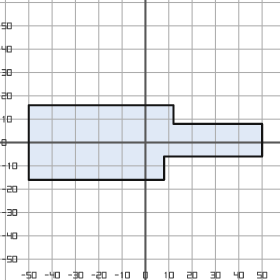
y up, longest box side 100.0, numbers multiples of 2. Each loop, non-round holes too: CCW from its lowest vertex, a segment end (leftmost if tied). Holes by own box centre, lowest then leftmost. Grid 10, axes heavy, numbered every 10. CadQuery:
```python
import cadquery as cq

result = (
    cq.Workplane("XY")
    .moveTo(-50.0, -16.0)
    .lineTo(8.0, -16.0)
    .lineTo(8.0, -6.0)
    .lineTo(50.0, -6.0)
    .lineTo(50.0, 8.0)
    .lineTo(12.0, 8.0)
    .lineTo(12.0, 16.0)
    .lineTo(-50.0, 16.0)
    .close()
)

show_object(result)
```